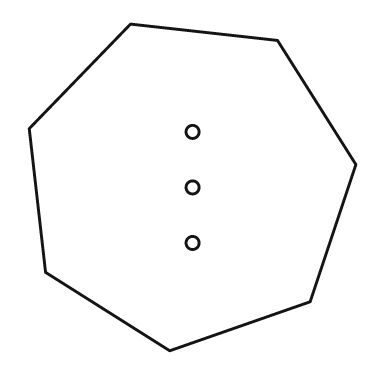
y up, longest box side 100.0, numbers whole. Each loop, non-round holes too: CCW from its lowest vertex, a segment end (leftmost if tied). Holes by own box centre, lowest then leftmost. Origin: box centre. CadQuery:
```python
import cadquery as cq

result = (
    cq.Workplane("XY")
    .moveTo(-7.0, -50.0)
    .lineTo(36.0, -35.0)
    .lineTo(50.0, 7.0)
    .lineTo(26.0, 45.0)
    .lineTo(-19.0, 50.0)
    .lineTo(-50.0, 18.0)
    .lineTo(-45.0, -26.0)
    .close()
    .moveTo(0.0, -17.0)
    .circle(2.0)
    .moveTo(0.0, 0.0)
    .circle(2.0)
    .moveTo(0.0, 17.0)
    .circle(2.0)
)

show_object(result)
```